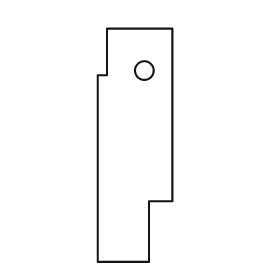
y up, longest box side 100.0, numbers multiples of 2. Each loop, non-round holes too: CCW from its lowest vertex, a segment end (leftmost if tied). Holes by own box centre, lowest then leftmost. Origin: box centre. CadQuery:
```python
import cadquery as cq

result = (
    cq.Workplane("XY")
    .moveTo(-16.0, -50.0)
    .lineTo(6.0, -50.0)
    .lineTo(6.0, -24.0)
    .lineTo(16.0, -24.0)
    .lineTo(16.0, 50.0)
    .lineTo(-12.0, 50.0)
    .lineTo(-12.0, 30.0)
    .lineTo(-16.0, 30.0)
    .close()
    .moveTo(4.0, 32.0)
    .circle(4.0)
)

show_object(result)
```